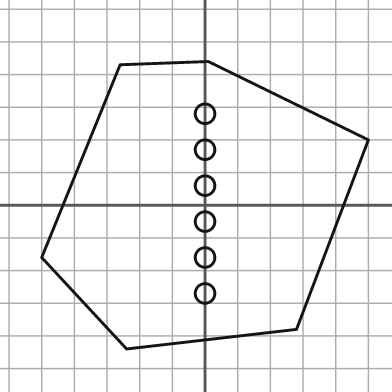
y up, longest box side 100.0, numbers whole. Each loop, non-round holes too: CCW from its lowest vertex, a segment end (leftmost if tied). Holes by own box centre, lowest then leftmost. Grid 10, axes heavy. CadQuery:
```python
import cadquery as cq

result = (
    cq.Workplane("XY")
    .moveTo(-24.0, -44.0)
    .lineTo(28.0, -38.0)
    .lineTo(50.0, 20.0)
    .lineTo(1.0, 44.0)
    .lineTo(-26.0, 43.0)
    .lineTo(-50.0, -16.0)
    .close()
    .moveTo(0.0, -27.0)
    .circle(3.0)
    .moveTo(0.0, -16.0)
    .circle(3.0)
    .moveTo(0.0, -5.0)
    .circle(3.0)
    .moveTo(0.0, 6.0)
    .circle(3.0)
    .moveTo(0.0, 17.0)
    .circle(3.0)
    .moveTo(0.0, 28.0)
    .circle(3.0)
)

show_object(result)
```